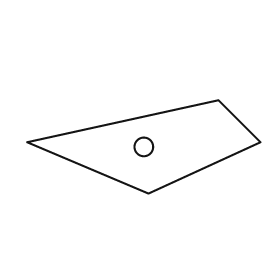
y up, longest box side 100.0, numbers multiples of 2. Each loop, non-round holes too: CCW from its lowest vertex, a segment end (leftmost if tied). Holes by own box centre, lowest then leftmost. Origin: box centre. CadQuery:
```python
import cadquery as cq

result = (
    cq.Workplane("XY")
    .moveTo(2.0, -20.0)
    .lineTo(50.0, 2.0)
    .lineTo(32.0, 20.0)
    .lineTo(-50.0, 2.0)
    .close()
    .moveTo(0.0, 0.0)
    .circle(4.0)
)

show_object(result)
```